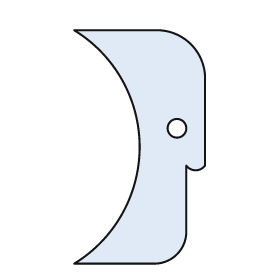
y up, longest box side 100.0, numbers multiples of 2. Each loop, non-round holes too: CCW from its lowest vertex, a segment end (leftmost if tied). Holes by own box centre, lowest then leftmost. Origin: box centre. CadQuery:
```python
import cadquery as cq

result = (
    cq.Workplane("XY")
    .moveTo(-28.0, -50.0)
    .lineTo(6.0, -50.0)
    .threePointArc((16.0, -46.0), (20.0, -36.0))
    .lineTo(20.0, -8.0)
    .threePointArc((24.0, -10.0), (28.0, -8.0))
    .lineTo(28.0, 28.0)
    .threePointArc((22.0, 44.0), (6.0, 50.0))
    .lineTo(-28.0, 50.0)
    .threePointArc((0.0, 0.0), (-28.0, -50.0))
    .close()
    .moveTo(16.0, 8.0)
    .circle(4.0)
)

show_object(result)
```